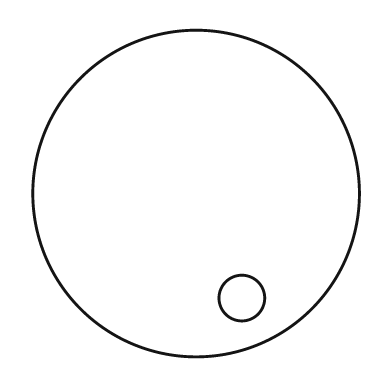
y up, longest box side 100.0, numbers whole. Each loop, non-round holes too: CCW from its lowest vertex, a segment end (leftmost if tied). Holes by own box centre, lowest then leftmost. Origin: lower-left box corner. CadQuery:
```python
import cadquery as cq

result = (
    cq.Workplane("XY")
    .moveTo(50.0, 50.0)
    .circle(50.0)
    .moveTo(64.0, 18.0)
    .circle(7.0)
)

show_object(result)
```